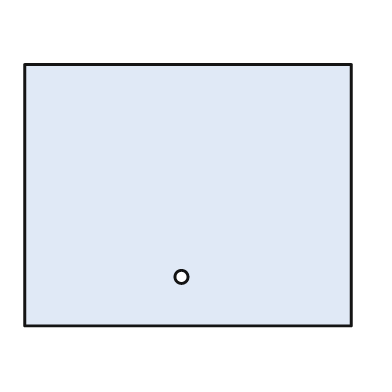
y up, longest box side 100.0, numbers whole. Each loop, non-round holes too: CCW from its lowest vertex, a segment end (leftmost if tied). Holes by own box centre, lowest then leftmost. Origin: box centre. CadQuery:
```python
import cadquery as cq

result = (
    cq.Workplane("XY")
    .moveTo(-50.0, -40.0)
    .lineTo(50.0, -40.0)
    .lineTo(50.0, 40.0)
    .lineTo(-50.0, 40.0)
    .close()
    .moveTo(-2.0, -25.0)
    .circle(2.0)
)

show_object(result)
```